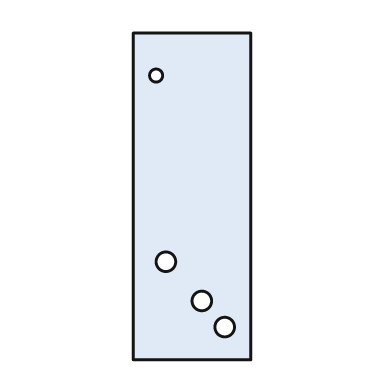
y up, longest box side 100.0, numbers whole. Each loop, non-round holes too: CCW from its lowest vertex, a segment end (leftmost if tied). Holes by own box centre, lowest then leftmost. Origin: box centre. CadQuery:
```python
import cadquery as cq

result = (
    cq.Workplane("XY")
    .moveTo(-18.0, -50.0)
    .lineTo(18.0, -50.0)
    .lineTo(18.0, 50.0)
    .lineTo(-18.0, 50.0)
    .close()
    .moveTo(10.0, -40.0)
    .circle(3.0)
    .moveTo(3.0, -32.0)
    .circle(3.0)
    .moveTo(-8.0, -20.0)
    .circle(3.0)
    .moveTo(-11.0, 37.0)
    .circle(2.0)
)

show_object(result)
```